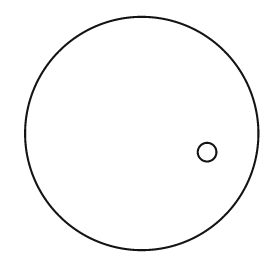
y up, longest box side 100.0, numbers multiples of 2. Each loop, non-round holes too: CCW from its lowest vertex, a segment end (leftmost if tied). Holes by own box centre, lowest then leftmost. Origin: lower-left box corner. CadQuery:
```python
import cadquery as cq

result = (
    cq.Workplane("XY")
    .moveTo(50.0, 50.0)
    .circle(50.0)
    .moveTo(78.0, 42.0)
    .circle(4.0)
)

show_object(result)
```